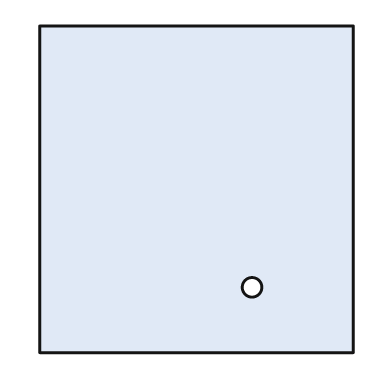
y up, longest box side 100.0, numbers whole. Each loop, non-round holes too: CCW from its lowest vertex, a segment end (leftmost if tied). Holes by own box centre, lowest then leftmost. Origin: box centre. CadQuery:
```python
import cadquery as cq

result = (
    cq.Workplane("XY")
    .moveTo(-48.0, -50.0)
    .lineTo(48.0, -50.0)
    .lineTo(48.0, 50.0)
    .lineTo(-48.0, 50.0)
    .close()
    .moveTo(17.0, -30.0)
    .circle(3.0)
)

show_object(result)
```